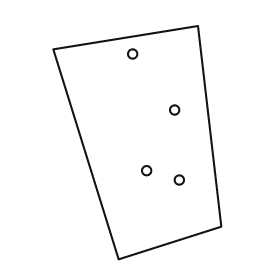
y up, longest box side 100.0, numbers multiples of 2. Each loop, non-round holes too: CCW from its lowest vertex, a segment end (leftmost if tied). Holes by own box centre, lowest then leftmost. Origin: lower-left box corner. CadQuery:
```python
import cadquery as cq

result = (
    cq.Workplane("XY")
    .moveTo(28.0, 0.0)
    .lineTo(72.0, 14.0)
    .lineTo(62.0, 100.0)
    .lineTo(0.0, 90.0)
    .close()
    .moveTo(54.0, 34.0)
    .circle(2.0)
    .moveTo(40.0, 38.0)
    .circle(2.0)
    .moveTo(52.0, 64.0)
    .circle(2.0)
    .moveTo(34.0, 88.0)
    .circle(2.0)
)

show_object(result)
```